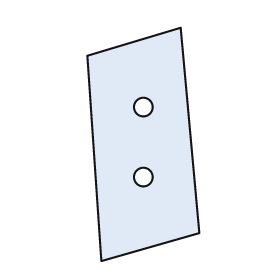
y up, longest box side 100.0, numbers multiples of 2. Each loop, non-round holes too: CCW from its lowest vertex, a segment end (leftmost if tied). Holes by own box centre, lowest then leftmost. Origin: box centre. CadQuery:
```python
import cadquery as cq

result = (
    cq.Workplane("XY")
    .moveTo(-18.0, -50.0)
    .lineTo(24.0, -38.0)
    .lineTo(16.0, 50.0)
    .lineTo(-24.0, 38.0)
    .close()
    .moveTo(0.0, -14.0)
    .circle(4.0)
    .moveTo(0.0, 16.0)
    .circle(4.0)
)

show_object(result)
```